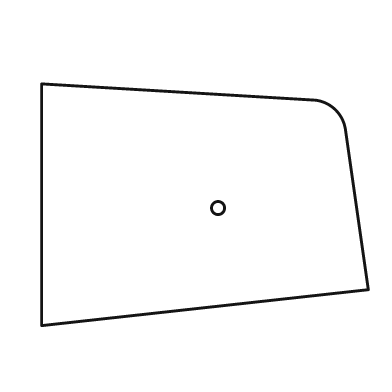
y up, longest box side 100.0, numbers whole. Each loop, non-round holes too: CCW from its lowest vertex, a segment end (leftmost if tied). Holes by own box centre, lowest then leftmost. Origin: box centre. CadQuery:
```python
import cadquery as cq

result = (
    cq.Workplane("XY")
    .moveTo(-50.0, -37.0)
    .lineTo(50.0, -26.0)
    .lineTo(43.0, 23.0)
    .threePointArc((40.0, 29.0), (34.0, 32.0))
    .lineTo(-50.0, 37.0)
    .close()
    .moveTo(4.0, -1.0)
    .circle(2.0)
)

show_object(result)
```